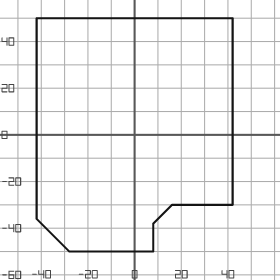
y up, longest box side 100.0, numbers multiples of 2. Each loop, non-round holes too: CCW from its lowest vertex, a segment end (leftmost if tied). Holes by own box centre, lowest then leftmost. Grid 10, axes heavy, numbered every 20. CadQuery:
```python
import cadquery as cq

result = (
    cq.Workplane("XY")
    .moveTo(-28.0, -50.0)
    .lineTo(8.0, -50.0)
    .lineTo(8.0, -38.0)
    .lineTo(16.0, -30.0)
    .lineTo(42.0, -30.0)
    .lineTo(42.0, 50.0)
    .lineTo(-42.0, 50.0)
    .lineTo(-42.0, -36.0)
    .close()
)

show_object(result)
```